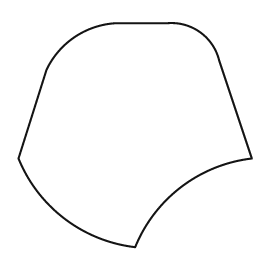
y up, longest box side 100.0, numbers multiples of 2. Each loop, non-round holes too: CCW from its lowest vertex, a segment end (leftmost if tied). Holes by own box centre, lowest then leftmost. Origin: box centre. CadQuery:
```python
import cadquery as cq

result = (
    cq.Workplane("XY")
    .moveTo(0.0, -48.0)
    .threePointArc((20.0, -22.0), (50.0, -10.0))
    .lineTo(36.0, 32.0)
    .threePointArc((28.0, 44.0), (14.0, 48.0))
    .lineTo(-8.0, 48.0)
    .threePointArc((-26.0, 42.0), (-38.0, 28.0))
    .lineTo(-50.0, -10.0)
    .threePointArc((-30.0, -36.0), (0.0, -48.0))
    .close()
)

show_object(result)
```